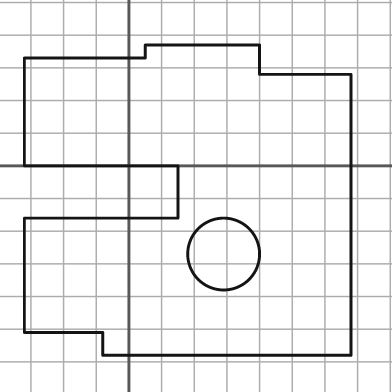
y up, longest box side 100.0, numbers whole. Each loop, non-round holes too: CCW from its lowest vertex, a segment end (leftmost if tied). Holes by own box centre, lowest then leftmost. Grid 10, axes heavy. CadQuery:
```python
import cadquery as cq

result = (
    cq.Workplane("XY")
    .moveTo(-8.0, -58.0)
    .lineTo(68.0, -58.0)
    .lineTo(68.0, 28.0)
    .lineTo(40.0, 28.0)
    .lineTo(40.0, 37.0)
    .lineTo(5.0, 37.0)
    .lineTo(5.0, 33.0)
    .lineTo(-32.0, 33.0)
    .lineTo(-32.0, 0.0)
    .lineTo(15.0, 0.0)
    .lineTo(15.0, -16.0)
    .lineTo(-32.0, -16.0)
    .lineTo(-32.0, -51.0)
    .lineTo(-8.0, -51.0)
    .close()
    .moveTo(29.0, -27.0)
    .circle(11.0)
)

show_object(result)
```